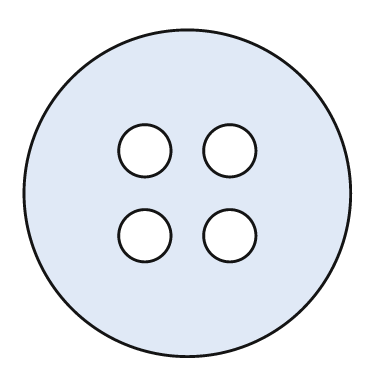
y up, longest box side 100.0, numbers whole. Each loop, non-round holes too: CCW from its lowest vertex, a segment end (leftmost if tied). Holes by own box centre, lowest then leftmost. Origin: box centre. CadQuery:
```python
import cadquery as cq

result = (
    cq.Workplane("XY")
    .moveTo(0.0, 0.0)
    .circle(50.0)
    .moveTo(-13.0, -13.0)
    .circle(8.0)
    .moveTo(13.0, -13.0)
    .circle(8.0)
    .moveTo(-13.0, 13.0)
    .circle(8.0)
    .moveTo(13.0, 13.0)
    .circle(8.0)
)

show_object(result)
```